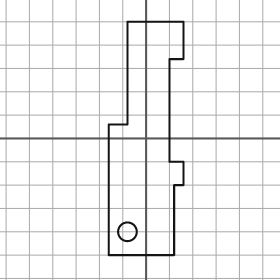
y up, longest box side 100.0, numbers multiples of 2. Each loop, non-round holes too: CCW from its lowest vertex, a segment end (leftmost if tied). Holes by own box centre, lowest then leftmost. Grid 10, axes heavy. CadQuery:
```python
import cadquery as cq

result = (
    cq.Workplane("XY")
    .moveTo(-16.0, -50.0)
    .lineTo(12.0, -50.0)
    .lineTo(12.0, -20.0)
    .lineTo(16.0, -20.0)
    .lineTo(16.0, -10.0)
    .lineTo(10.0, -10.0)
    .lineTo(10.0, 34.0)
    .lineTo(16.0, 34.0)
    .lineTo(16.0, 50.0)
    .lineTo(-8.0, 50.0)
    .lineTo(-8.0, 6.0)
    .lineTo(-16.0, 6.0)
    .close()
    .moveTo(-8.0, -40.0)
    .circle(4.0)
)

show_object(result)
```